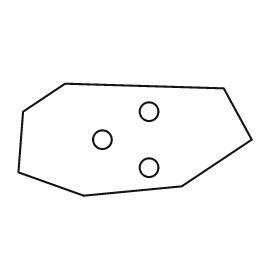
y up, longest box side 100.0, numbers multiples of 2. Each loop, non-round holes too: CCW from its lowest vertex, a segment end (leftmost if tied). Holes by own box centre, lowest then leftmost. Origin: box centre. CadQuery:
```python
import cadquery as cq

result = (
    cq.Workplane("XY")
    .moveTo(-22.0, -24.0)
    .lineTo(20.0, -20.0)
    .lineTo(50.0, 0.0)
    .lineTo(38.0, 22.0)
    .lineTo(-30.0, 24.0)
    .lineTo(-48.0, 12.0)
    .lineTo(-50.0, -14.0)
    .close()
    .moveTo(6.0, -12.0)
    .circle(4.0)
    .moveTo(-14.0, 0.0)
    .circle(4.0)
    .moveTo(6.0, 12.0)
    .circle(4.0)
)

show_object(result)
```